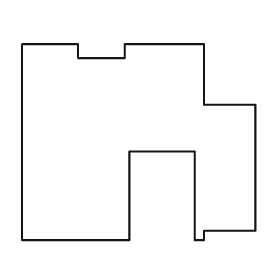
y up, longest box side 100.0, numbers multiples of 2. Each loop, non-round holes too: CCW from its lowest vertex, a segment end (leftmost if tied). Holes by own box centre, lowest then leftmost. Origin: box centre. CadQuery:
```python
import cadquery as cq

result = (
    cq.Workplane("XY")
    .moveTo(-50.0, -42.0)
    .lineTo(-4.0, -42.0)
    .lineTo(-4.0, -4.0)
    .lineTo(24.0, -4.0)
    .lineTo(24.0, -42.0)
    .lineTo(28.0, -42.0)
    .lineTo(28.0, -38.0)
    .lineTo(50.0, -38.0)
    .lineTo(50.0, 16.0)
    .lineTo(28.0, 16.0)
    .lineTo(28.0, 42.0)
    .lineTo(-6.0, 42.0)
    .lineTo(-6.0, 36.0)
    .lineTo(-26.0, 36.0)
    .lineTo(-26.0, 42.0)
    .lineTo(-50.0, 42.0)
    .close()
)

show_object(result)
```